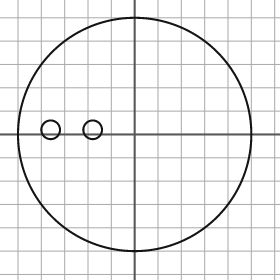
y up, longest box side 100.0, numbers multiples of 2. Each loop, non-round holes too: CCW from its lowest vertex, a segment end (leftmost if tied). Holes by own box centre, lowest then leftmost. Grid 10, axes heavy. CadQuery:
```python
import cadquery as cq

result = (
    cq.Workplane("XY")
    .moveTo(0.0, 0.0)
    .circle(50.0)
    .moveTo(-36.0, 2.0)
    .circle(4.0)
    .moveTo(-18.0, 2.0)
    .circle(4.0)
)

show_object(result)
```